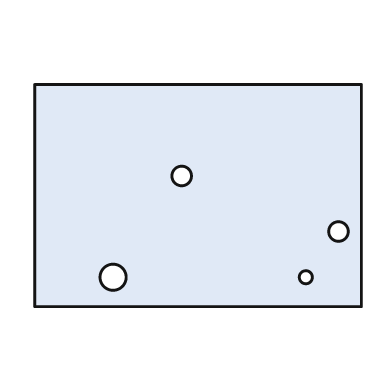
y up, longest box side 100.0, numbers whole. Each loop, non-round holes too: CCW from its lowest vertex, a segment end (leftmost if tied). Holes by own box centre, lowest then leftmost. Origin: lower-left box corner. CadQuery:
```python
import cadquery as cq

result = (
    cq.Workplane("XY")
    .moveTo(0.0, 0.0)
    .lineTo(100.0, 0.0)
    .lineTo(100.0, 68.0)
    .lineTo(0.0, 68.0)
    .close()
    .moveTo(24.0, 9.0)
    .circle(4.0)
    .moveTo(83.0, 9.0)
    .circle(2.0)
    .moveTo(93.0, 23.0)
    .circle(3.0)
    .moveTo(45.0, 40.0)
    .circle(3.0)
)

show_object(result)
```